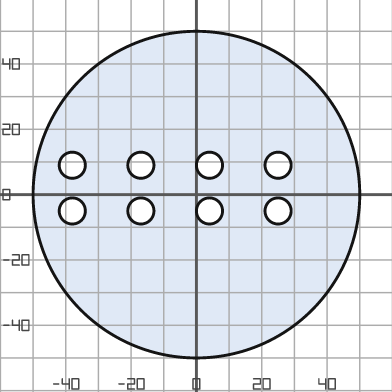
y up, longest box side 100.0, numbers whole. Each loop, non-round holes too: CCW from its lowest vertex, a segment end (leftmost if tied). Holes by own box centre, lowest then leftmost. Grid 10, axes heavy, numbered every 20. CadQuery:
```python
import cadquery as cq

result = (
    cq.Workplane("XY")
    .moveTo(0.0, 0.0)
    .circle(50.0)
    .moveTo(-38.0, -5.0)
    .circle(4.0)
    .moveTo(-17.0, -5.0)
    .circle(4.0)
    .moveTo(4.0, -5.0)
    .circle(4.0)
    .moveTo(25.0, -5.0)
    .circle(4.0)
    .moveTo(-38.0, 9.0)
    .circle(4.0)
    .moveTo(-17.0, 9.0)
    .circle(4.0)
    .moveTo(4.0, 9.0)
    .circle(4.0)
    .moveTo(25.0, 9.0)
    .circle(4.0)
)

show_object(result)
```